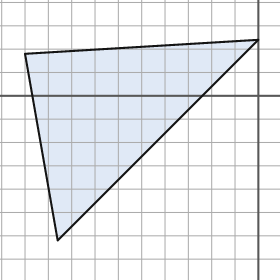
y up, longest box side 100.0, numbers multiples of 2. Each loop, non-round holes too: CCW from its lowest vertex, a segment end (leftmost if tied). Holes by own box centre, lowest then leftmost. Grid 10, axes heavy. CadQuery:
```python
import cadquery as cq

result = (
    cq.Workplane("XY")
    .moveTo(-86.0, -62.0)
    .lineTo(0.0, 24.0)
    .lineTo(-100.0, 18.0)
    .close()
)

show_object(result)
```